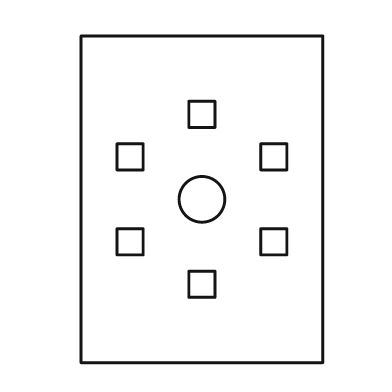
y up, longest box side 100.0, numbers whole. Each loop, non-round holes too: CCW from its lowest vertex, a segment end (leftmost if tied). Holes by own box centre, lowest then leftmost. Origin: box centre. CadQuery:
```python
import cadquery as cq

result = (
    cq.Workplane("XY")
    .moveTo(-37.0, -50.0)
    .lineTo(37.0, -50.0)
    .lineTo(37.0, 50.0)
    .lineTo(-37.0, 50.0)
    .close()
    .moveTo(-4.0, -30.0)
    .lineTo(4.0, -30.0)
    .lineTo(4.0, -22.0)
    .lineTo(-4.0, -22.0)
    .close()
    .moveTo(-26.0, -17.0)
    .lineTo(-18.0, -17.0)
    .lineTo(-18.0, -9.0)
    .lineTo(-26.0, -9.0)
    .close()
    .moveTo(18.0, -17.0)
    .lineTo(26.0, -17.0)
    .lineTo(26.0, -9.0)
    .lineTo(18.0, -9.0)
    .close()
    .moveTo(0.0, 0.0)
    .circle(7.0)
    .moveTo(-26.0, 9.0)
    .lineTo(-18.0, 9.0)
    .lineTo(-18.0, 17.0)
    .lineTo(-26.0, 17.0)
    .close()
    .moveTo(18.0, 9.0)
    .lineTo(26.0, 9.0)
    .lineTo(26.0, 17.0)
    .lineTo(18.0, 17.0)
    .close()
    .moveTo(-4.0, 22.0)
    .lineTo(4.0, 22.0)
    .lineTo(4.0, 30.0)
    .lineTo(-4.0, 30.0)
    .close()
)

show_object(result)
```